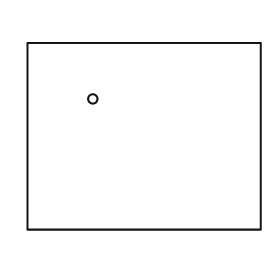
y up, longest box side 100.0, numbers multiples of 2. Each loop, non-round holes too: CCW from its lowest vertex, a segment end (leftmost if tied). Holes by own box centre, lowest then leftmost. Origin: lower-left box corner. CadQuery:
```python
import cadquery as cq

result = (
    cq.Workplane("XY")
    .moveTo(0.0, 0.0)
    .lineTo(100.0, 0.0)
    .lineTo(100.0, 80.0)
    .lineTo(0.0, 80.0)
    .close()
    .moveTo(28.0, 56.0)
    .circle(2.0)
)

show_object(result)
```